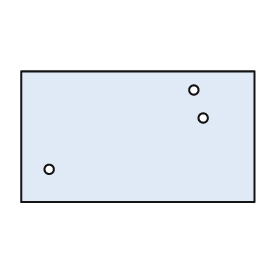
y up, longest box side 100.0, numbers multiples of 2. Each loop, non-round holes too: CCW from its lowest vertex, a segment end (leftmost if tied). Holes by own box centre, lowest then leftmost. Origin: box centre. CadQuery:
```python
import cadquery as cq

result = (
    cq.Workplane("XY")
    .moveTo(-50.0, -28.0)
    .lineTo(50.0, -28.0)
    .lineTo(50.0, 28.0)
    .lineTo(-50.0, 28.0)
    .close()
    .moveTo(-38.0, -14.0)
    .circle(2.0)
    .moveTo(28.0, 8.0)
    .circle(2.0)
    .moveTo(24.0, 20.0)
    .circle(2.0)
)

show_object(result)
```